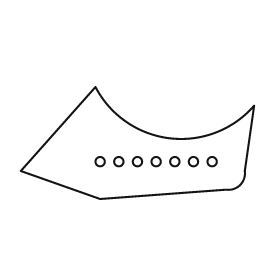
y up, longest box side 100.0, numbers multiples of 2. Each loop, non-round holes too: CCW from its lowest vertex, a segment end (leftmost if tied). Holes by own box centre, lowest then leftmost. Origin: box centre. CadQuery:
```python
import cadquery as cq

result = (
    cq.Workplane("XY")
    .moveTo(-16.0, -24.0)
    .lineTo(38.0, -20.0)
    .threePointArc((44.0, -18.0), (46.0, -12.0))
    .lineTo(50.0, 16.0)
    .threePointArc((14.0, 2.0), (-18.0, 24.0))
    .lineTo(-50.0, -12.0)
    .close()
    .moveTo(-16.0, -8.0)
    .circle(2.0)
    .moveTo(-8.0, -8.0)
    .circle(2.0)
    .moveTo(0.0, -8.0)
    .circle(2.0)
    .moveTo(8.0, -8.0)
    .circle(2.0)
    .moveTo(16.0, -8.0)
    .circle(2.0)
    .moveTo(24.0, -8.0)
    .circle(2.0)
    .moveTo(32.0, -8.0)
    .circle(2.0)
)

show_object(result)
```